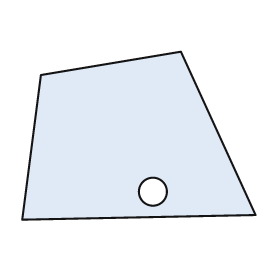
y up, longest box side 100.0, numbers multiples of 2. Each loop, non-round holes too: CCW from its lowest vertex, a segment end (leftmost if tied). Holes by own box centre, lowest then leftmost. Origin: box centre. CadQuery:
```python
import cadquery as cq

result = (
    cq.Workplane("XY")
    .moveTo(-50.0, -36.0)
    .lineTo(50.0, -34.0)
    .lineTo(18.0, 36.0)
    .lineTo(-42.0, 26.0)
    .close()
    .moveTo(6.0, -24.0)
    .circle(6.0)
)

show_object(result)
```